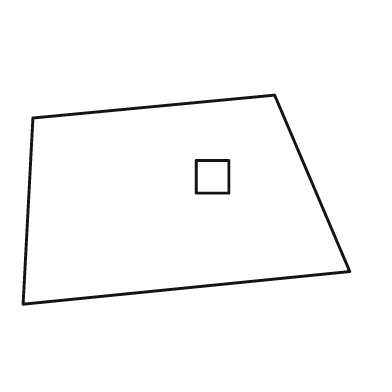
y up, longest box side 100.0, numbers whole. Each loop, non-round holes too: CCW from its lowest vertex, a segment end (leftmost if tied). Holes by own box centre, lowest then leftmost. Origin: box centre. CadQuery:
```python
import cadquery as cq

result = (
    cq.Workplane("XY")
    .moveTo(-50.0, -32.0)
    .lineTo(50.0, -22.0)
    .lineTo(27.0, 32.0)
    .lineTo(-47.0, 25.0)
    .close()
    .moveTo(3.0, 2.0)
    .lineTo(13.0, 2.0)
    .lineTo(13.0, 12.0)
    .lineTo(3.0, 12.0)
    .close()
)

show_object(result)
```